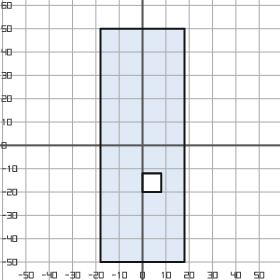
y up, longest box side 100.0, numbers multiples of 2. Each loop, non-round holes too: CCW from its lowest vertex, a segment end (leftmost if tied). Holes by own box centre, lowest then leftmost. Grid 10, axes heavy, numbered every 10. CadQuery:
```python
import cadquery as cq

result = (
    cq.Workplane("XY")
    .moveTo(-18.0, -50.0)
    .lineTo(18.0, -50.0)
    .lineTo(18.0, 50.0)
    .lineTo(-18.0, 50.0)
    .close()
    .moveTo(0.0, -20.0)
    .lineTo(8.0, -20.0)
    .lineTo(8.0, -12.0)
    .lineTo(0.0, -12.0)
    .close()
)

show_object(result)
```